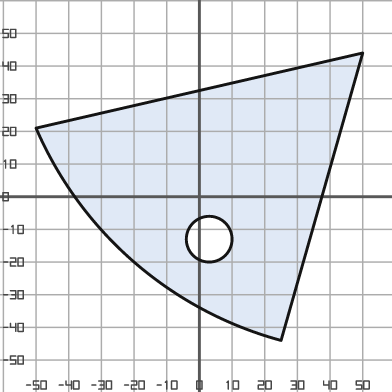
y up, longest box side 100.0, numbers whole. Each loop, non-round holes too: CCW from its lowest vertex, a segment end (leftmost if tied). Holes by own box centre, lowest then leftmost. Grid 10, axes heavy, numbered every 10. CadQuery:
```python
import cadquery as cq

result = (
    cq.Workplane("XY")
    .moveTo(25.0, -44.0)
    .lineTo(50.0, 44.0)
    .lineTo(-50.0, 21.0)
    .threePointArc((-20.0, -20.0), (25.0, -44.0))
    .close()
    .moveTo(3.0, -13.0)
    .circle(7.0)
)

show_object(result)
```